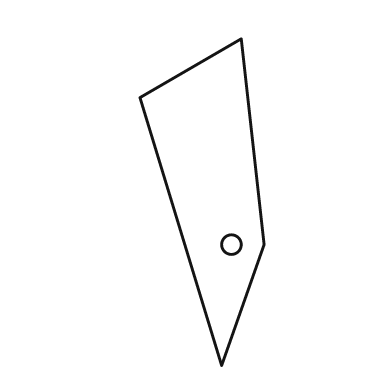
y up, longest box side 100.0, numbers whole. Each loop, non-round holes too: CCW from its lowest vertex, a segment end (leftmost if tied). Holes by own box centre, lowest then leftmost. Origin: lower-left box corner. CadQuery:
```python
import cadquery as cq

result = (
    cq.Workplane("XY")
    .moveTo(25.0, 0.0)
    .lineTo(38.0, 37.0)
    .lineTo(31.0, 100.0)
    .lineTo(0.0, 82.0)
    .close()
    .moveTo(28.0, 37.0)
    .circle(3.0)
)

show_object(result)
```